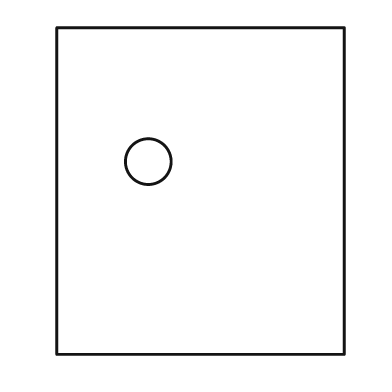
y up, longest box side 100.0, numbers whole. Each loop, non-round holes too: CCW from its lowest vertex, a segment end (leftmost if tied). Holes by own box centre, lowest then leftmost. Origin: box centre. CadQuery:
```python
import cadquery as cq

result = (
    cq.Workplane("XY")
    .moveTo(-44.0, -50.0)
    .lineTo(44.0, -50.0)
    .lineTo(44.0, 50.0)
    .lineTo(-44.0, 50.0)
    .close()
    .moveTo(-16.0, 9.0)
    .circle(7.0)
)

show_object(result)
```